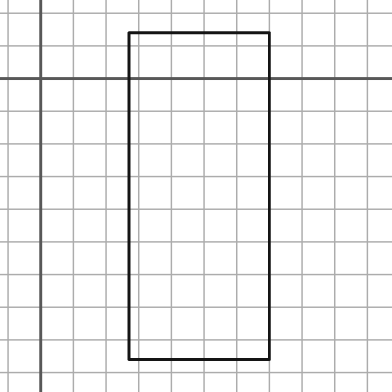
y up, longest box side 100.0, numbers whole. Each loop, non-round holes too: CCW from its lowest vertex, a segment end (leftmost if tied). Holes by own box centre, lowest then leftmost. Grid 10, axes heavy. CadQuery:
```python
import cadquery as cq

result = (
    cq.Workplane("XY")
    .moveTo(27.0, -86.0)
    .lineTo(70.0, -86.0)
    .lineTo(70.0, 14.0)
    .lineTo(27.0, 14.0)
    .close()
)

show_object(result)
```